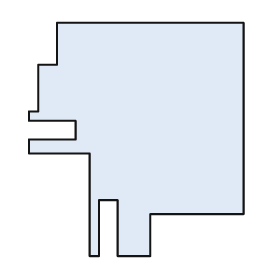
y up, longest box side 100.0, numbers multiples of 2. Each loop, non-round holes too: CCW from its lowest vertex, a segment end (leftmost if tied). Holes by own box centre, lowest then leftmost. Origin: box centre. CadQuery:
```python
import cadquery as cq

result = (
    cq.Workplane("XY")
    .moveTo(-20.0, -50.0)
    .lineTo(-16.0, -50.0)
    .lineTo(-16.0, -26.0)
    .lineTo(-8.0, -26.0)
    .lineTo(-8.0, -50.0)
    .lineTo(6.0, -50.0)
    .lineTo(6.0, -32.0)
    .lineTo(46.0, -32.0)
    .lineTo(46.0, 50.0)
    .lineTo(-34.0, 50.0)
    .lineTo(-34.0, 32.0)
    .lineTo(-42.0, 32.0)
    .lineTo(-42.0, 12.0)
    .lineTo(-46.0, 12.0)
    .lineTo(-46.0, 8.0)
    .lineTo(-26.0, 8.0)
    .lineTo(-26.0, 0.0)
    .lineTo(-46.0, 0.0)
    .lineTo(-46.0, -6.0)
    .lineTo(-20.0, -6.0)
    .close()
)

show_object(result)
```